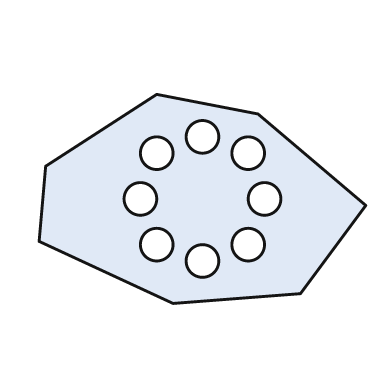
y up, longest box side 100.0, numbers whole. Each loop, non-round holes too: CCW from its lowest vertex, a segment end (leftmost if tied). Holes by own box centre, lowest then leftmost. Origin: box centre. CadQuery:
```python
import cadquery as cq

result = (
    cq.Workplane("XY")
    .moveTo(-9.0, -32.0)
    .lineTo(30.0, -29.0)
    .lineTo(50.0, -2.0)
    .lineTo(17.0, 26.0)
    .lineTo(-14.0, 32.0)
    .lineTo(-48.0, 10.0)
    .lineTo(-50.0, -13.0)
    .close()
    .moveTo(0.0, -19.0)
    .circle(5.0)
    .moveTo(-14.0, -14.0)
    .circle(5.0)
    .moveTo(14.0, -14.0)
    .circle(5.0)
    .moveTo(-19.0, 0.0)
    .circle(5.0)
    .moveTo(19.0, 0.0)
    .circle(5.0)
    .moveTo(-14.0, 14.0)
    .circle(5.0)
    .moveTo(14.0, 14.0)
    .circle(5.0)
    .moveTo(0.0, 19.0)
    .circle(5.0)
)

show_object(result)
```